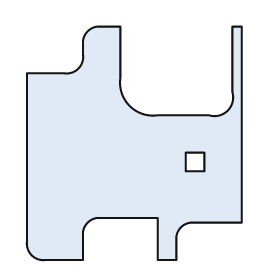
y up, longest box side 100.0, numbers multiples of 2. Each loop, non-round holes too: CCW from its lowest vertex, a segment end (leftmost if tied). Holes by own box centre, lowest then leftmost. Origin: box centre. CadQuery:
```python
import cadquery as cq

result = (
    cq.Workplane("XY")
    .moveTo(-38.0, -50.0)
    .lineTo(-22.0, -50.0)
    .lineTo(-22.0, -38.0)
    .threePointArc((-20.0, -34.0), (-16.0, -32.0))
    .lineTo(10.0, -32.0)
    .lineTo(10.0, -50.0)
    .lineTo(18.0, -50.0)
    .lineTo(18.0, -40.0)
    .threePointArc((20.0, -36.0), (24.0, -34.0))
    .lineTo(46.0, -34.0)
    .lineTo(46.0, 50.0)
    .lineTo(42.0, 50.0)
    .lineTo(42.0, 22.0)
    .threePointArc((40.0, 14.0), (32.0, 12.0))
    .lineTo(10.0, 12.0)
    .threePointArc((-2.0, 16.0), (-6.0, 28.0))
    .lineTo(-6.0, 50.0)
    .lineTo(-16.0, 50.0)
    .threePointArc((-20.0, 48.0), (-22.0, 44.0))
    .lineTo(-22.0, 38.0)
    .threePointArc((-24.0, 32.0), (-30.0, 30.0))
    .lineTo(-46.0, 30.0)
    .lineTo(-46.0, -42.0)
    .threePointArc((-44.0, -48.0), (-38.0, -50.0))
    .close()
    .moveTo(22.0, -12.0)
    .lineTo(30.0, -12.0)
    .lineTo(30.0, -4.0)
    .lineTo(22.0, -4.0)
    .close()
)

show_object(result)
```